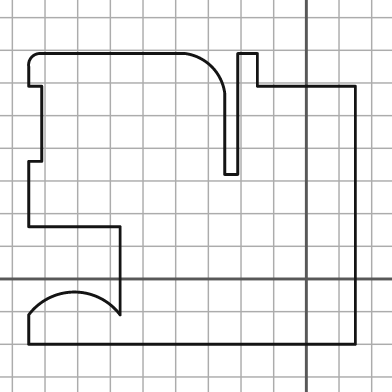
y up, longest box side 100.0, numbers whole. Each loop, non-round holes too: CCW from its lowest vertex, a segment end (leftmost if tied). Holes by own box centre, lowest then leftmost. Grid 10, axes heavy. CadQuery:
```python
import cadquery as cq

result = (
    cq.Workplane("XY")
    .moveTo(-85.0, -20.0)
    .lineTo(15.0, -20.0)
    .lineTo(15.0, 59.0)
    .lineTo(-15.0, 59.0)
    .lineTo(-15.0, 69.0)
    .lineTo(-21.0, 69.0)
    .lineTo(-21.0, 32.0)
    .lineTo(-25.0, 32.0)
    .lineTo(-25.0, 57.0)
    .threePointArc((-29.0, 65.0), (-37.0, 69.0))
    .lineTo(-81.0, 69.0)
    .threePointArc((-84.0, 68.0), (-85.0, 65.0))
    .lineTo(-85.0, 59.0)
    .lineTo(-81.0, 59.0)
    .lineTo(-81.0, 36.0)
    .lineTo(-85.0, 36.0)
    .lineTo(-85.0, 16.0)
    .lineTo(-57.0, 16.0)
    .lineTo(-57.0, -11.0)
    .threePointArc((-71.0, -4.0), (-85.0, -11.0))
    .close()
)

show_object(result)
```